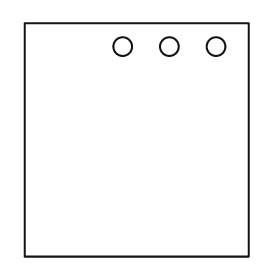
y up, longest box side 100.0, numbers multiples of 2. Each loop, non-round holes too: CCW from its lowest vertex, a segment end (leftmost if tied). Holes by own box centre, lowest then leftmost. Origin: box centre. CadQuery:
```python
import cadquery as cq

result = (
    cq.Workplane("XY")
    .moveTo(-48.0, -50.0)
    .lineTo(48.0, -50.0)
    .lineTo(48.0, 50.0)
    .lineTo(-48.0, 50.0)
    .close()
    .moveTo(-6.0, 40.0)
    .circle(4.0)
    .moveTo(14.0, 40.0)
    .circle(4.0)
    .moveTo(34.0, 40.0)
    .circle(4.0)
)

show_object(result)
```